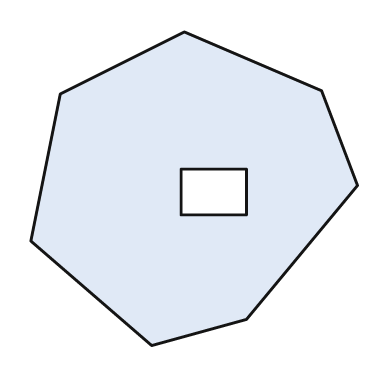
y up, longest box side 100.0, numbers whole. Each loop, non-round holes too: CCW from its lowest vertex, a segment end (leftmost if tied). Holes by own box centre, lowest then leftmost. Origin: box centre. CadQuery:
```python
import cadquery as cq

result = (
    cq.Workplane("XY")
    .moveTo(-13.0, -48.0)
    .lineTo(16.0, -40.0)
    .lineTo(50.0, 1.0)
    .lineTo(39.0, 30.0)
    .lineTo(-3.0, 48.0)
    .lineTo(-41.0, 29.0)
    .lineTo(-50.0, -16.0)
    .close()
    .moveTo(-4.0, -8.0)
    .lineTo(16.0, -8.0)
    .lineTo(16.0, 6.0)
    .lineTo(-4.0, 6.0)
    .close()
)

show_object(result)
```